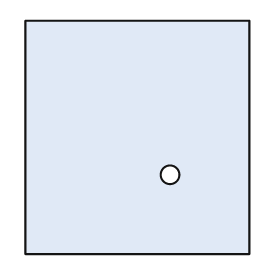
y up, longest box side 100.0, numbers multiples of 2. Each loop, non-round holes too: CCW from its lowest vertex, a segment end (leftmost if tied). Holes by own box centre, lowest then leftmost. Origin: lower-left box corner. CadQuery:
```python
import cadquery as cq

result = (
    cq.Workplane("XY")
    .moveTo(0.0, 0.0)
    .lineTo(96.0, 0.0)
    .lineTo(96.0, 100.0)
    .lineTo(0.0, 100.0)
    .close()
    .moveTo(62.0, 34.0)
    .circle(4.0)
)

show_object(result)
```